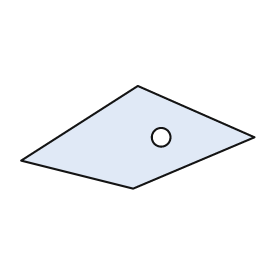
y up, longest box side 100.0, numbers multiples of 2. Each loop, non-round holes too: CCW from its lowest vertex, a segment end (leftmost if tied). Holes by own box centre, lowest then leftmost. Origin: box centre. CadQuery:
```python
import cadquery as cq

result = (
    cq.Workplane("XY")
    .moveTo(-2.0, -22.0)
    .lineTo(50.0, 0.0)
    .lineTo(0.0, 22.0)
    .lineTo(-50.0, -10.0)
    .close()
    .moveTo(10.0, 0.0)
    .circle(4.0)
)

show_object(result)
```